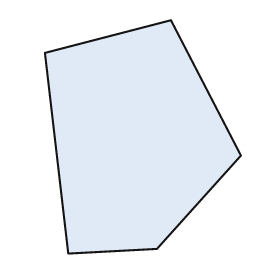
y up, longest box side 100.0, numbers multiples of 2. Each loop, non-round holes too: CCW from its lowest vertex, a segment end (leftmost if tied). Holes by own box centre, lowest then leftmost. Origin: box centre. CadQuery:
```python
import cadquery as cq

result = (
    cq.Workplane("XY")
    .moveTo(-32.0, -50.0)
    .lineTo(6.0, -48.0)
    .lineTo(42.0, -8.0)
    .lineTo(12.0, 50.0)
    .lineTo(-42.0, 36.0)
    .close()
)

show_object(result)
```